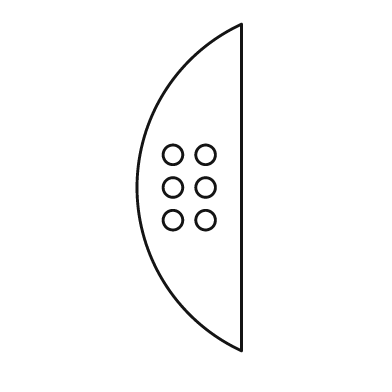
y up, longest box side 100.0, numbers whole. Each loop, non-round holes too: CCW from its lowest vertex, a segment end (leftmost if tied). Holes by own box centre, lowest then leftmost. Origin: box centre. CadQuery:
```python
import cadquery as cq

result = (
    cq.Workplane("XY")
    .moveTo(16.0, -50.0)
    .lineTo(16.0, 50.0)
    .threePointArc((-16.0, 0.0), (16.0, -50.0))
    .close()
    .moveTo(-5.0, -10.0)
    .circle(3.0)
    .moveTo(5.0, -10.0)
    .circle(3.0)
    .moveTo(-5.0, 0.0)
    .circle(3.0)
    .moveTo(5.0, 0.0)
    .circle(3.0)
    .moveTo(-5.0, 10.0)
    .circle(3.0)
    .moveTo(5.0, 10.0)
    .circle(3.0)
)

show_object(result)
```